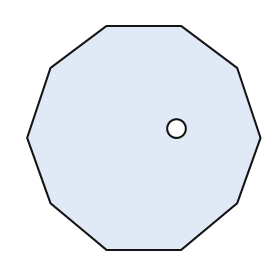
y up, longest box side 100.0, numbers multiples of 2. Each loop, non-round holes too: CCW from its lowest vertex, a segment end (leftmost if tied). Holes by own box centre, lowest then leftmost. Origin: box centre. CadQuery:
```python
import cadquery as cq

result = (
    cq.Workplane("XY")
    .moveTo(-16.0, -48.0)
    .lineTo(16.0, -48.0)
    .lineTo(40.0, -28.0)
    .lineTo(50.0, 0.0)
    .lineTo(40.0, 30.0)
    .lineTo(16.0, 48.0)
    .lineTo(-16.0, 48.0)
    .lineTo(-40.0, 30.0)
    .lineTo(-50.0, 0.0)
    .lineTo(-40.0, -28.0)
    .close()
    .moveTo(14.0, 4.0)
    .circle(4.0)
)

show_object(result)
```